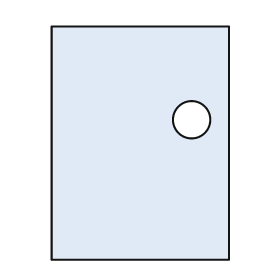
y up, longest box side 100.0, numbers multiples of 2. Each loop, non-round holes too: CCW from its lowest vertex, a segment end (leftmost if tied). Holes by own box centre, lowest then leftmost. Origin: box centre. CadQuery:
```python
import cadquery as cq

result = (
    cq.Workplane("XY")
    .moveTo(-38.0, -50.0)
    .lineTo(38.0, -50.0)
    .lineTo(38.0, 50.0)
    .lineTo(-38.0, 50.0)
    .close()
    .moveTo(22.0, 10.0)
    .circle(8.0)
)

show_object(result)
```